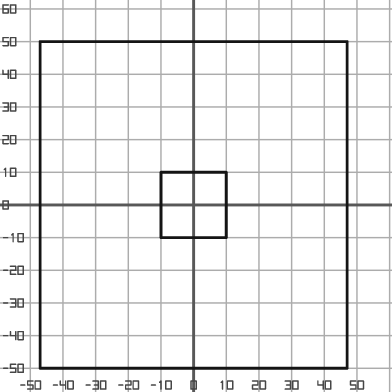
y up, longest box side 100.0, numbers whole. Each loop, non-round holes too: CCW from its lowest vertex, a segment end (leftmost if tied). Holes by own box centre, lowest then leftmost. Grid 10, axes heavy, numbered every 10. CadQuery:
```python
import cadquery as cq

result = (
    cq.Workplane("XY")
    .moveTo(-47.0, -50.0)
    .lineTo(47.0, -50.0)
    .lineTo(47.0, 50.0)
    .lineTo(-47.0, 50.0)
    .close()
    .moveTo(-10.0, -10.0)
    .lineTo(10.0, -10.0)
    .lineTo(10.0, 10.0)
    .lineTo(-10.0, 10.0)
    .close()
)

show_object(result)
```